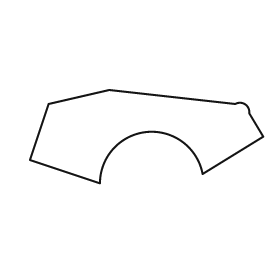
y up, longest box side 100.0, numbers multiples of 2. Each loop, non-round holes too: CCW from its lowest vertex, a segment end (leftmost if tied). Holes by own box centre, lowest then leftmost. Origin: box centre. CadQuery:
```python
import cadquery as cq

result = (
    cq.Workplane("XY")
    .moveTo(-20.0, -20.0)
    .threePointArc((0.0, 2.0), (24.0, -16.0))
    .lineTo(50.0, 0.0)
    .lineTo(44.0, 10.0)
    .threePointArc((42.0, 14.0), (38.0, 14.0))
    .lineTo(-16.0, 20.0)
    .lineTo(-42.0, 14.0)
    .lineTo(-50.0, -10.0)
    .close()
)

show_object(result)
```